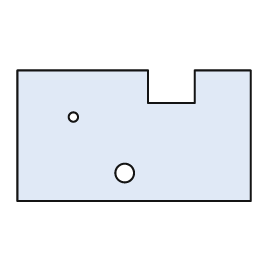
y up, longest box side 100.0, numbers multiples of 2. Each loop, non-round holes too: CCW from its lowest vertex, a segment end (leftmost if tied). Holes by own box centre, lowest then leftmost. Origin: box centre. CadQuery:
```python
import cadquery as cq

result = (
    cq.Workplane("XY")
    .moveTo(-50.0, -28.0)
    .lineTo(50.0, -28.0)
    .lineTo(50.0, 28.0)
    .lineTo(26.0, 28.0)
    .lineTo(26.0, 14.0)
    .lineTo(6.0, 14.0)
    .lineTo(6.0, 28.0)
    .lineTo(-50.0, 28.0)
    .close()
    .moveTo(-4.0, -16.0)
    .circle(4.0)
    .moveTo(-26.0, 8.0)
    .circle(2.0)
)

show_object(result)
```